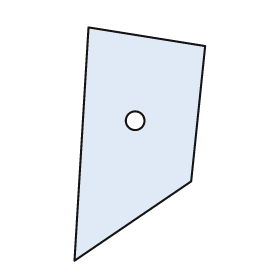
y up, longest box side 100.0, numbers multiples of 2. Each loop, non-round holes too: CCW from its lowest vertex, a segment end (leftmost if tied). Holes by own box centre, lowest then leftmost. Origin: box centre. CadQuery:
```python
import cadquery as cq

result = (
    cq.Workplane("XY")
    .moveTo(-28.0, -50.0)
    .lineTo(22.0, -16.0)
    .lineTo(28.0, 42.0)
    .lineTo(-22.0, 50.0)
    .close()
    .moveTo(-2.0, 10.0)
    .circle(4.0)
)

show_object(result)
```